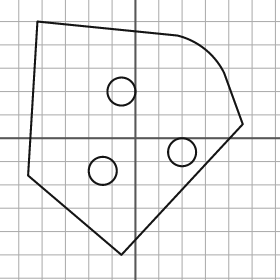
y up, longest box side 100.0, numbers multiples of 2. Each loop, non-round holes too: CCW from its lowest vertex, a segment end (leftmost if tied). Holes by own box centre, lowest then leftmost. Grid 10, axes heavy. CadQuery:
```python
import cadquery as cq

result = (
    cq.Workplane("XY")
    .moveTo(-6.0, -50.0)
    .lineTo(46.0, 6.0)
    .lineTo(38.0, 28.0)
    .threePointArc((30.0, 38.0), (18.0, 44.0))
    .lineTo(-42.0, 50.0)
    .lineTo(-46.0, -16.0)
    .close()
    .moveTo(-14.0, -14.0)
    .circle(6.0)
    .moveTo(20.0, -6.0)
    .circle(6.0)
    .moveTo(-6.0, 20.0)
    .circle(6.0)
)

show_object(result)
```